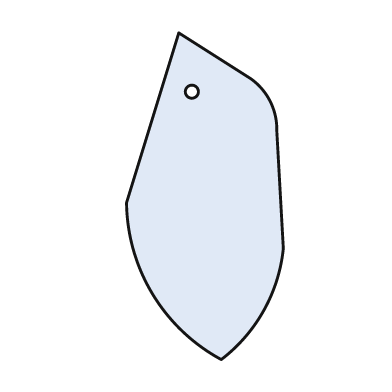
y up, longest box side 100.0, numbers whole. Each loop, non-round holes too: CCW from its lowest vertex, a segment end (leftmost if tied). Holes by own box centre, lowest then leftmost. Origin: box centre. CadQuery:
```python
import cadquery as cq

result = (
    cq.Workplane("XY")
    .moveTo(5.0, -50.0)
    .threePointArc((18.0, -35.0), (24.0, -16.0))
    .lineTo(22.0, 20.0)
    .threePointArc((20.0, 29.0), (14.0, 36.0))
    .lineTo(-8.0, 50.0)
    .lineTo(-24.0, -2.0)
    .threePointArc((-16.0, -30.0), (5.0, -50.0))
    .close()
    .moveTo(-4.0, 32.0)
    .circle(2.0)
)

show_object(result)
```